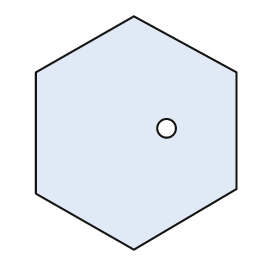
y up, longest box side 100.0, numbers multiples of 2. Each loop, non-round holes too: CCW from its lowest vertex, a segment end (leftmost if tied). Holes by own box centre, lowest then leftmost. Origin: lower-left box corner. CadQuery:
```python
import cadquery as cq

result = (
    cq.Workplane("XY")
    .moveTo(42.0, 0.0)
    .lineTo(86.0, 26.0)
    .lineTo(86.0, 76.0)
    .lineTo(42.0, 100.0)
    .lineTo(0.0, 76.0)
    .lineTo(0.0, 24.0)
    .close()
    .moveTo(56.0, 52.0)
    .circle(4.0)
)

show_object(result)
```